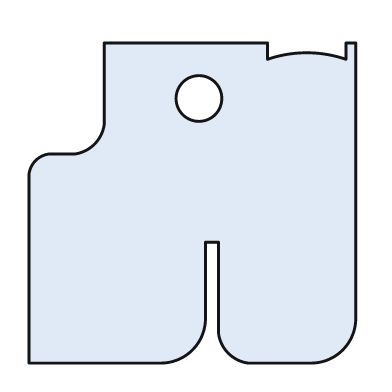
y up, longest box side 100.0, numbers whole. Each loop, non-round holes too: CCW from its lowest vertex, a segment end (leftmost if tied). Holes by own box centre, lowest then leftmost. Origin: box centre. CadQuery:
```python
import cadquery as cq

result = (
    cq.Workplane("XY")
    .moveTo(-50.0, -49.0)
    .lineTo(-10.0, -49.0)
    .threePointArc((0.0, -45.0), (4.0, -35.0))
    .lineTo(4.0, -12.0)
    .lineTo(8.0, -12.0)
    .lineTo(8.0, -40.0)
    .threePointArc((11.0, -46.0), (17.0, -49.0))
    .lineTo(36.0, -49.0)
    .threePointArc((46.0, -45.0), (50.0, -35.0))
    .lineTo(50.0, 49.0)
    .lineTo(47.0, 49.0)
    .lineTo(47.0, 44.0)
    .threePointArc((35.0, 46.0), (23.0, 44.0))
    .lineTo(23.0, 49.0)
    .lineTo(-27.0, 49.0)
    .lineTo(-27.0, 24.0)
    .threePointArc((-30.0, 18.0), (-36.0, 15.0))
    .lineTo(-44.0, 15.0)
    .threePointArc((-48.0, 13.0), (-50.0, 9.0))
    .close()
    .moveTo(2.0, 32.0)
    .circle(7.0)
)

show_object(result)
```